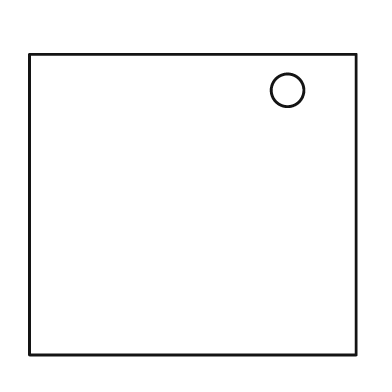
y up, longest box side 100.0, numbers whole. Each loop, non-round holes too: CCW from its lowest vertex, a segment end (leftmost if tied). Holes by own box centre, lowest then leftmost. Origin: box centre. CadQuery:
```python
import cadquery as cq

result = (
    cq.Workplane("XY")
    .moveTo(-50.0, -46.0)
    .lineTo(50.0, -46.0)
    .lineTo(50.0, 46.0)
    .lineTo(-50.0, 46.0)
    .close()
    .moveTo(29.0, 35.0)
    .circle(5.0)
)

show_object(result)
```